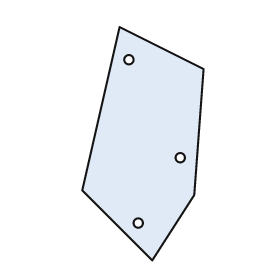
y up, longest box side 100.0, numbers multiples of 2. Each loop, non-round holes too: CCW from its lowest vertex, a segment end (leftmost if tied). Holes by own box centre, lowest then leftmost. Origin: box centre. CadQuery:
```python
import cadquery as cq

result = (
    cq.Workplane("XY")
    .moveTo(4.0, -50.0)
    .lineTo(22.0, -22.0)
    .lineTo(26.0, 32.0)
    .lineTo(-10.0, 50.0)
    .lineTo(-26.0, -20.0)
    .close()
    .moveTo(-2.0, -34.0)
    .circle(2.0)
    .moveTo(16.0, -6.0)
    .circle(2.0)
    .moveTo(-6.0, 36.0)
    .circle(2.0)
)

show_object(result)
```